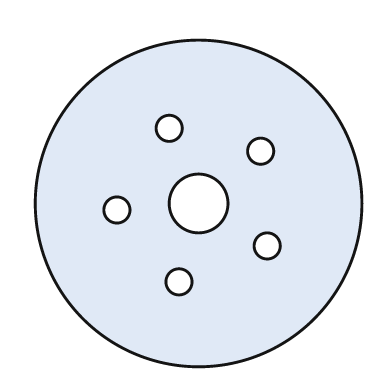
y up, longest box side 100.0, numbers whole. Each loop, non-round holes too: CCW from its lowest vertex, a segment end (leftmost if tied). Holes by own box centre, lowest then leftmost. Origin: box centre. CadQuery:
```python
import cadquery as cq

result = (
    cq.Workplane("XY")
    .moveTo(0.0, 0.0)
    .circle(50.0)
    .moveTo(-6.0, -24.0)
    .circle(4.0)
    .moveTo(21.0, -13.0)
    .circle(4.0)
    .moveTo(-25.0, -2.0)
    .circle(4.0)
    .moveTo(0.0, 0.0)
    .circle(9.0)
    .moveTo(19.0, 16.0)
    .circle(4.0)
    .moveTo(-9.0, 23.0)
    .circle(4.0)
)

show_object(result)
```